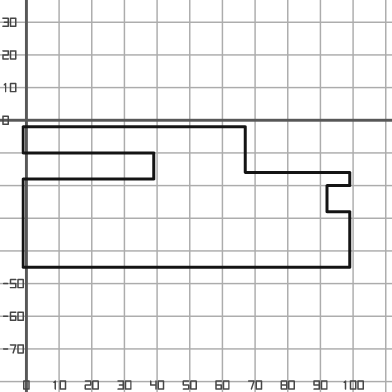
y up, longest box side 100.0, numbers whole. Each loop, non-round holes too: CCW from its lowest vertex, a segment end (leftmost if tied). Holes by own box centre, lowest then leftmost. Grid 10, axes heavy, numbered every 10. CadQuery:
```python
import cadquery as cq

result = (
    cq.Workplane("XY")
    .moveTo(-1.0, -45.0)
    .lineTo(99.0, -45.0)
    .lineTo(99.0, -28.0)
    .lineTo(92.0, -28.0)
    .lineTo(92.0, -20.0)
    .lineTo(99.0, -20.0)
    .lineTo(99.0, -16.0)
    .lineTo(67.0, -16.0)
    .lineTo(67.0, -2.0)
    .lineTo(-1.0, -2.0)
    .lineTo(-1.0, -10.0)
    .lineTo(39.0, -10.0)
    .lineTo(39.0, -18.0)
    .lineTo(-1.0, -18.0)
    .close()
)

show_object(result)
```